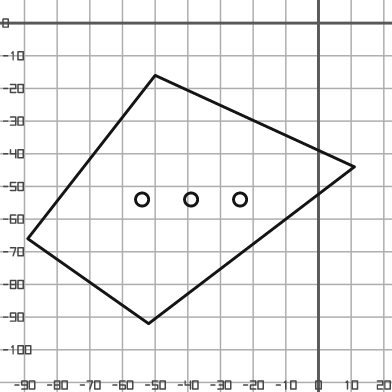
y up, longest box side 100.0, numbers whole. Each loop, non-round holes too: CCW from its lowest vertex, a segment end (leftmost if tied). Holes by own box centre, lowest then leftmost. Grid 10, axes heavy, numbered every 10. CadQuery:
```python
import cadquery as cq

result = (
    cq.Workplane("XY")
    .moveTo(-52.0, -92.0)
    .lineTo(11.0, -44.0)
    .lineTo(-50.0, -16.0)
    .lineTo(-89.0, -66.0)
    .close()
    .moveTo(-54.0, -54.0)
    .circle(2.0)
    .moveTo(-39.0, -54.0)
    .circle(2.0)
    .moveTo(-24.0, -54.0)
    .circle(2.0)
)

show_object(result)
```